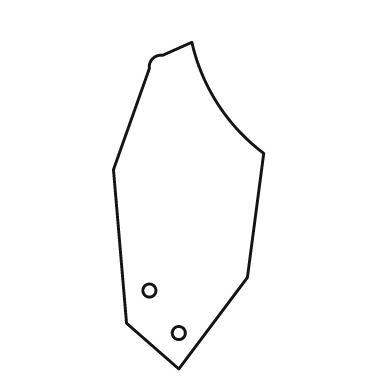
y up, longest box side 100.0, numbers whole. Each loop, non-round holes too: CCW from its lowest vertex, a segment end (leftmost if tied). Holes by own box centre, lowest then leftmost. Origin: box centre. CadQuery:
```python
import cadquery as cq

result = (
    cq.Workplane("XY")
    .moveTo(-3.0, -50.0)
    .lineTo(18.0, -22.0)
    .lineTo(23.0, 16.0)
    .threePointArc((9.0, 31.0), (1.0, 50.0))
    .lineTo(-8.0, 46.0)
    .threePointArc((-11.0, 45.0), (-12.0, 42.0))
    .lineTo(-23.0, 11.0)
    .lineTo(-19.0, -36.0)
    .close()
    .moveTo(-3.0, -39.0)
    .circle(2.0)
    .moveTo(-12.0, -26.0)
    .circle(2.0)
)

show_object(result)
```